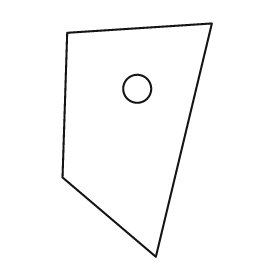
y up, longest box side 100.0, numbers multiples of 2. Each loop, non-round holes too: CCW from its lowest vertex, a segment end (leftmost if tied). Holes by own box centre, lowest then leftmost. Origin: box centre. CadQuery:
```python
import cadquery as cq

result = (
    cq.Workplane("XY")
    .moveTo(8.0, -50.0)
    .lineTo(32.0, 50.0)
    .lineTo(-30.0, 46.0)
    .lineTo(-32.0, -16.0)
    .close()
    .moveTo(0.0, 22.0)
    .circle(6.0)
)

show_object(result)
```